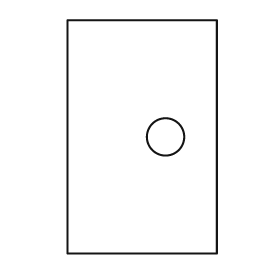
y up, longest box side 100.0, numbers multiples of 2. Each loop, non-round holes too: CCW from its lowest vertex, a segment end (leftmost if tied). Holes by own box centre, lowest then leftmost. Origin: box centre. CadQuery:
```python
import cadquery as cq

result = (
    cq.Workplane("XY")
    .moveTo(-32.0, -50.0)
    .lineTo(32.0, -50.0)
    .lineTo(32.0, 50.0)
    .lineTo(-32.0, 50.0)
    .close()
    .moveTo(10.0, 0.0)
    .circle(8.0)
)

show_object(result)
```